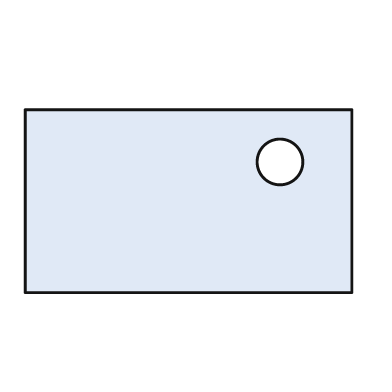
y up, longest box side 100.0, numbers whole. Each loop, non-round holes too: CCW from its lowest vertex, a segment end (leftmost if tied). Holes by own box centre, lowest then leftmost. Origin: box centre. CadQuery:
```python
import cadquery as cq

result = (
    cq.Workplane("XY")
    .moveTo(-50.0, -28.0)
    .lineTo(50.0, -28.0)
    .lineTo(50.0, 28.0)
    .lineTo(-50.0, 28.0)
    .close()
    .moveTo(28.0, 12.0)
    .circle(7.0)
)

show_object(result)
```